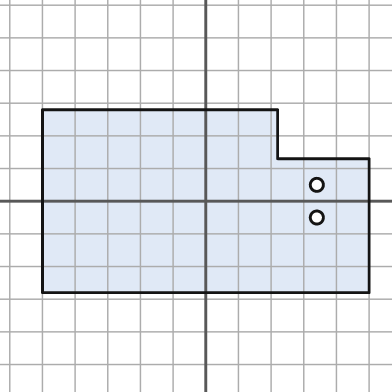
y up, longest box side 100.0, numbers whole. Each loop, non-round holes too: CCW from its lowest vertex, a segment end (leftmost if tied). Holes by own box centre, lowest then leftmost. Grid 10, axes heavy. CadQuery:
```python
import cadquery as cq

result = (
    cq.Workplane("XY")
    .moveTo(-50.0, -28.0)
    .lineTo(50.0, -28.0)
    .lineTo(50.0, 13.0)
    .lineTo(22.0, 13.0)
    .lineTo(22.0, 28.0)
    .lineTo(-50.0, 28.0)
    .close()
    .moveTo(34.0, -5.0)
    .circle(2.0)
    .moveTo(34.0, 5.0)
    .circle(2.0)
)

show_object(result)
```